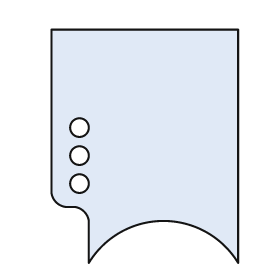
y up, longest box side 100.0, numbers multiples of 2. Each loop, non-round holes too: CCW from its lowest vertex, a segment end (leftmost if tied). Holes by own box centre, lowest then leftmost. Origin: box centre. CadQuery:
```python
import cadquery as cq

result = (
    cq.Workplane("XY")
    .moveTo(-24.0, -50.0)
    .threePointArc((8.0, -32.0), (40.0, -50.0))
    .lineTo(40.0, 50.0)
    .lineTo(-40.0, 50.0)
    .lineTo(-40.0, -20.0)
    .threePointArc((-38.0, -24.0), (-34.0, -26.0))
    .lineTo(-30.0, -26.0)
    .threePointArc((-26.0, -28.0), (-24.0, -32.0))
    .close()
    .moveTo(-28.0, -16.0)
    .circle(4.0)
    .moveTo(-28.0, -4.0)
    .circle(4.0)
    .moveTo(-28.0, 8.0)
    .circle(4.0)
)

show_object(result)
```